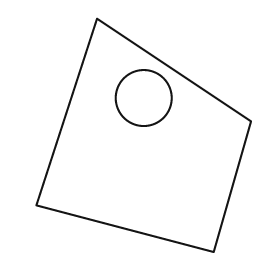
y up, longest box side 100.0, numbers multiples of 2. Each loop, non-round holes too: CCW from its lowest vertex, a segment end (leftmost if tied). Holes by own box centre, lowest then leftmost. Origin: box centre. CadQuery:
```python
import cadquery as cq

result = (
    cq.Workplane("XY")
    .moveTo(30.0, -50.0)
    .lineTo(46.0, 6.0)
    .lineTo(-20.0, 50.0)
    .lineTo(-46.0, -30.0)
    .close()
    .moveTo(0.0, 16.0)
    .circle(12.0)
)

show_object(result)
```